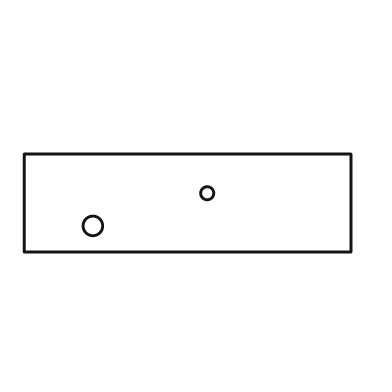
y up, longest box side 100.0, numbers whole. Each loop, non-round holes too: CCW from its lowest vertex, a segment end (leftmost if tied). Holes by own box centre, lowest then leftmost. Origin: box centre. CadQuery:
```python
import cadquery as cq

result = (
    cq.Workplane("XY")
    .moveTo(-50.0, -15.0)
    .lineTo(50.0, -15.0)
    .lineTo(50.0, 15.0)
    .lineTo(-50.0, 15.0)
    .close()
    .moveTo(-29.0, -7.0)
    .circle(3.0)
    .moveTo(6.0, 3.0)
    .circle(2.0)
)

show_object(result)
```